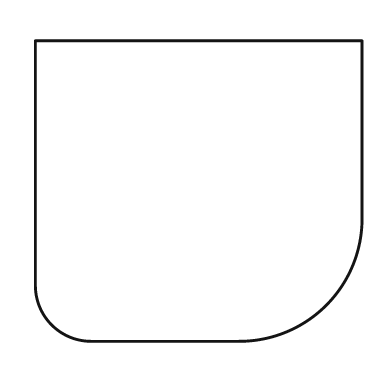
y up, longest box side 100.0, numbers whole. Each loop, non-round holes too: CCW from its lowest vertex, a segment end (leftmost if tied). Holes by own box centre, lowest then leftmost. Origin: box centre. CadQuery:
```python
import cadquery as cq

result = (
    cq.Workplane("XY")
    .moveTo(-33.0, -46.0)
    .lineTo(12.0, -46.0)
    .threePointArc((39.0, -35.0), (50.0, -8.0))
    .lineTo(50.0, 46.0)
    .lineTo(-50.0, 46.0)
    .lineTo(-50.0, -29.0)
    .threePointArc((-45.0, -41.0), (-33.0, -46.0))
    .close()
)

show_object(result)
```